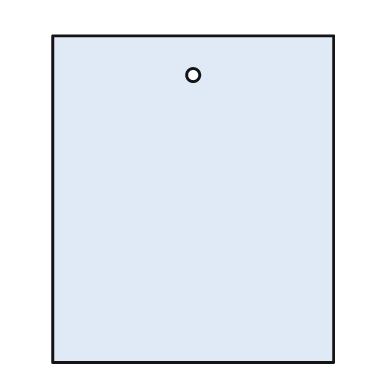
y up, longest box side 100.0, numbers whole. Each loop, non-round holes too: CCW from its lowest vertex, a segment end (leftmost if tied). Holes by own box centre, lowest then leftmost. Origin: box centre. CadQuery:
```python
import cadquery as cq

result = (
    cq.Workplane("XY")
    .moveTo(-43.0, -50.0)
    .lineTo(43.0, -50.0)
    .lineTo(43.0, 50.0)
    .lineTo(-43.0, 50.0)
    .close()
    .moveTo(0.0, 38.0)
    .circle(2.0)
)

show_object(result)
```